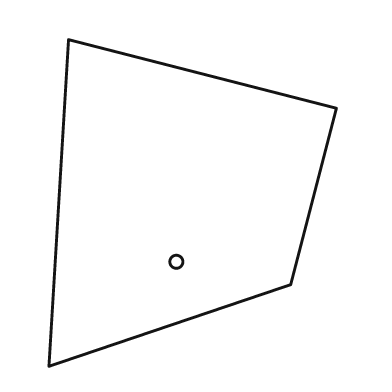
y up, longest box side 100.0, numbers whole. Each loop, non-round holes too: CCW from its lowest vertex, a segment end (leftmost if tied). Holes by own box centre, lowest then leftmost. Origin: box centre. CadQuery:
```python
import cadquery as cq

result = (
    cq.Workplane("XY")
    .moveTo(-44.0, -50.0)
    .lineTo(30.0, -25.0)
    .lineTo(44.0, 29.0)
    .lineTo(-38.0, 50.0)
    .close()
    .moveTo(-5.0, -18.0)
    .circle(2.0)
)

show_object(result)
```